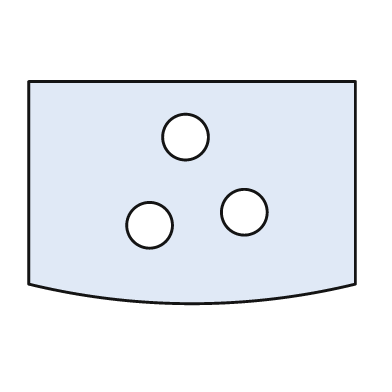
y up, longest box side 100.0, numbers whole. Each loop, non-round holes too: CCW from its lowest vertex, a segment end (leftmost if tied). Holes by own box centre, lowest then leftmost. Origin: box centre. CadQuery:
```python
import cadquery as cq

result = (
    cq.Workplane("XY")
    .moveTo(-50.0, -28.0)
    .threePointArc((0.0, -34.0), (50.0, -28.0))
    .lineTo(50.0, 34.0)
    .lineTo(-50.0, 34.0)
    .close()
    .moveTo(-13.0, -10.0)
    .circle(7.0)
    .moveTo(16.0, -6.0)
    .circle(7.0)
    .moveTo(-2.0, 17.0)
    .circle(7.0)
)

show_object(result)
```